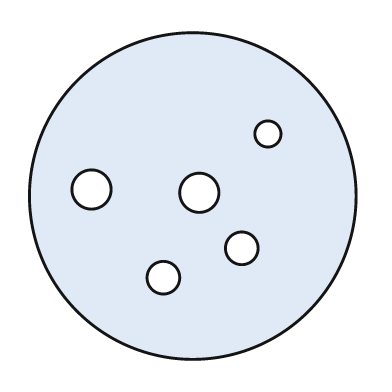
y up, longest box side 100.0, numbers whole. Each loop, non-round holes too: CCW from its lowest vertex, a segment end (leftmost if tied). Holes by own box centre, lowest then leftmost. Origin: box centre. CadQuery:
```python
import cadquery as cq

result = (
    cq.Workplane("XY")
    .moveTo(0.0, 0.0)
    .circle(50.0)
    .moveTo(-9.0, -25.0)
    .circle(5.0)
    .moveTo(15.0, -16.0)
    .circle(5.0)
    .moveTo(2.0, 1.0)
    .circle(6.0)
    .moveTo(-31.0, 2.0)
    .circle(6.0)
    .moveTo(23.0, 19.0)
    .circle(4.0)
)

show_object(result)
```